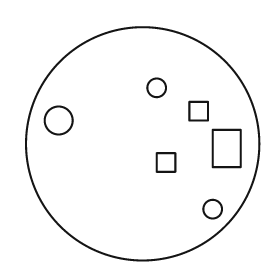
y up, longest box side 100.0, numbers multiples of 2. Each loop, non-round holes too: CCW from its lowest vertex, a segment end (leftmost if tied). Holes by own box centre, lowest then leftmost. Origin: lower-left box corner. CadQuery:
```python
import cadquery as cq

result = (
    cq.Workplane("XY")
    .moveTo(50.0, 50.0)
    .circle(50.0)
    .moveTo(80.0, 22.0)
    .circle(4.0)
    .moveTo(56.0, 38.0)
    .lineTo(64.0, 38.0)
    .lineTo(64.0, 46.0)
    .lineTo(56.0, 46.0)
    .close()
    .moveTo(80.0, 40.0)
    .lineTo(92.0, 40.0)
    .lineTo(92.0, 56.0)
    .lineTo(80.0, 56.0)
    .close()
    .moveTo(14.0, 60.0)
    .circle(6.0)
    .moveTo(70.0, 60.0)
    .lineTo(78.0, 60.0)
    .lineTo(78.0, 68.0)
    .lineTo(70.0, 68.0)
    .close()
    .moveTo(56.0, 74.0)
    .circle(4.0)
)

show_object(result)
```